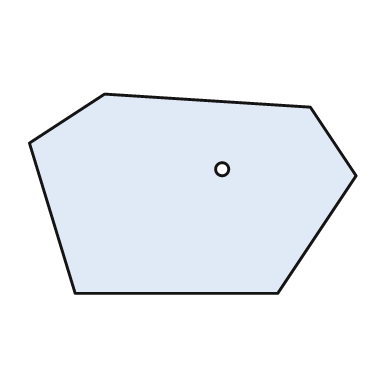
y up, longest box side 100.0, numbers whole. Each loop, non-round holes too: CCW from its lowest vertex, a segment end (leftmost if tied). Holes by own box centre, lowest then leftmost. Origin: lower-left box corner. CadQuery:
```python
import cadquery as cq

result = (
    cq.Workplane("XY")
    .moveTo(14.0, 0.0)
    .lineTo(76.0, 0.0)
    .lineTo(100.0, 36.0)
    .lineTo(86.0, 57.0)
    .lineTo(23.0, 61.0)
    .lineTo(0.0, 46.0)
    .close()
    .moveTo(59.0, 38.0)
    .circle(2.0)
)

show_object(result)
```